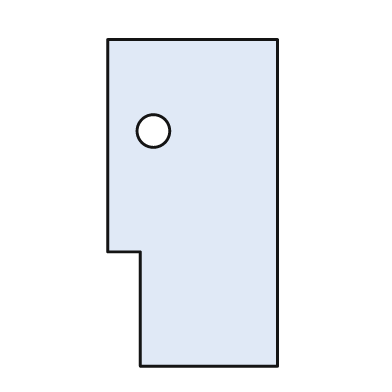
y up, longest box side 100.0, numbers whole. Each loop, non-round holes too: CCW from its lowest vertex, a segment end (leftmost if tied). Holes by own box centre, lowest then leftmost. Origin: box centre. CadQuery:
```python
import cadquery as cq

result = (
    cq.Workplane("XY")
    .moveTo(-16.0, -50.0)
    .lineTo(26.0, -50.0)
    .lineTo(26.0, 50.0)
    .lineTo(-26.0, 50.0)
    .lineTo(-26.0, -15.0)
    .lineTo(-16.0, -15.0)
    .close()
    .moveTo(-12.0, 22.0)
    .circle(5.0)
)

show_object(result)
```